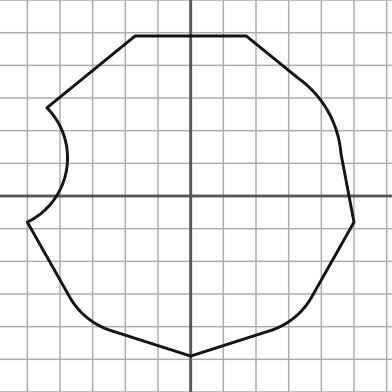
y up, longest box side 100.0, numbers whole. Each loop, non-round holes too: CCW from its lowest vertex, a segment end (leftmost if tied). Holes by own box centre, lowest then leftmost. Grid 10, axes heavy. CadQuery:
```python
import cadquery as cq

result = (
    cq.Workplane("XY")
    .moveTo(0.0, -49.0)
    .lineTo(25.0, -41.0)
    .threePointArc((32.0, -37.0), (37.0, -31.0))
    .lineTo(50.0, -8.0)
    .lineTo(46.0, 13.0)
    .threePointArc((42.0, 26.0), (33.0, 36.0))
    .lineTo(17.0, 49.0)
    .lineTo(-17.0, 49.0)
    .lineTo(-44.0, 27.0)
    .threePointArc((-38.0, 8.0), (-50.0, -8.0))
    .lineTo(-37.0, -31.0)
    .threePointArc((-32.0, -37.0), (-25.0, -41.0))
    .close()
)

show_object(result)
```